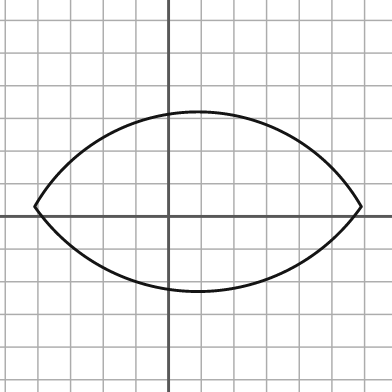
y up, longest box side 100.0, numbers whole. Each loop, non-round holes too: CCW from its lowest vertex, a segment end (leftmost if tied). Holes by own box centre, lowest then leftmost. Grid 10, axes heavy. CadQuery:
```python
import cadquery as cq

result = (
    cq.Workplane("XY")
    .moveTo(-41.0, 3.0)
    .threePointArc((9.0, -23.0), (59.0, 3.0))
    .threePointArc((9.0, 32.0), (-41.0, 3.0))
    .close()
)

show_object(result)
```